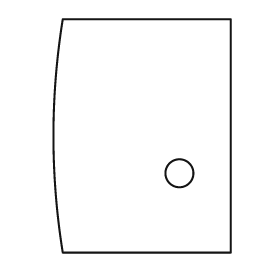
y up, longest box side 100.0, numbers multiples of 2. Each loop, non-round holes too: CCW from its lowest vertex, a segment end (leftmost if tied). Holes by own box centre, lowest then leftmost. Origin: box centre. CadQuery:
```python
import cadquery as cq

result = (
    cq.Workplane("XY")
    .moveTo(-34.0, -50.0)
    .lineTo(38.0, -50.0)
    .lineTo(38.0, 50.0)
    .lineTo(-34.0, 50.0)
    .threePointArc((-38.0, 0.0), (-34.0, -50.0))
    .close()
    .moveTo(16.0, -16.0)
    .circle(6.0)
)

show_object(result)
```